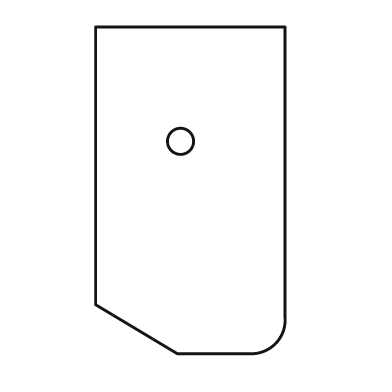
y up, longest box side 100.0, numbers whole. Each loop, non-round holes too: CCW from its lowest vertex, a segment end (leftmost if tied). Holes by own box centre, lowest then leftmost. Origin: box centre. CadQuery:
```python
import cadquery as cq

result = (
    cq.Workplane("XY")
    .moveTo(-4.0, -50.0)
    .lineTo(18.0, -50.0)
    .threePointArc((26.0, -47.0), (29.0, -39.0))
    .lineTo(29.0, 50.0)
    .lineTo(-29.0, 50.0)
    .lineTo(-29.0, -35.0)
    .close()
    .moveTo(-3.0, 15.0)
    .circle(4.0)
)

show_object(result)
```